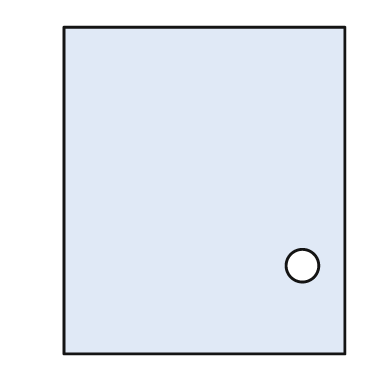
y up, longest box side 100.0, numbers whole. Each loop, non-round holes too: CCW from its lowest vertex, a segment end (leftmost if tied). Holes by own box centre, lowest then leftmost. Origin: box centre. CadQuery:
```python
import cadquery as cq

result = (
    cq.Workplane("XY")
    .moveTo(-43.0, -50.0)
    .lineTo(43.0, -50.0)
    .lineTo(43.0, 50.0)
    .lineTo(-43.0, 50.0)
    .close()
    .moveTo(30.0, -23.0)
    .circle(5.0)
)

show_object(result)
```